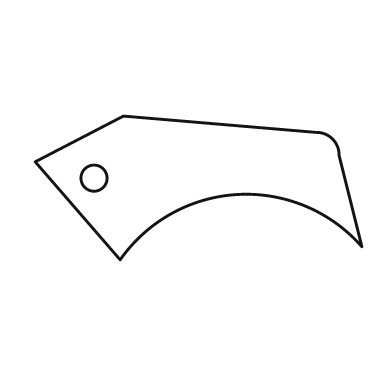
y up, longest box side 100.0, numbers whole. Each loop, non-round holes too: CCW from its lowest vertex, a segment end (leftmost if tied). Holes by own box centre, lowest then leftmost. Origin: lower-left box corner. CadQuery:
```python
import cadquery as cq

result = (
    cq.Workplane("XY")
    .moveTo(26.0, 0.0)
    .threePointArc((62.0, 20.0), (100.0, 4.0))
    .lineTo(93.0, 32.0)
    .threePointArc((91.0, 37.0), (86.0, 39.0))
    .lineTo(27.0, 44.0)
    .lineTo(0.0, 30.0)
    .close()
    .moveTo(18.0, 25.0)
    .circle(4.0)
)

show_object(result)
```